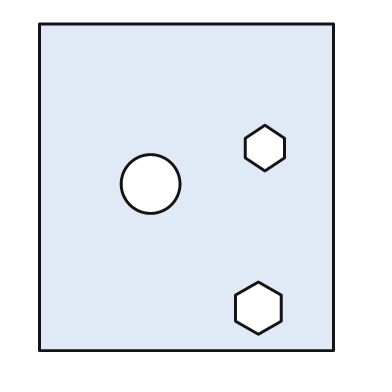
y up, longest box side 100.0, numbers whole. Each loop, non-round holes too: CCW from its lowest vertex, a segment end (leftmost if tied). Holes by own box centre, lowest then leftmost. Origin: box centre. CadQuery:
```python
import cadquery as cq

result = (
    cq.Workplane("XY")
    .moveTo(-45.0, -50.0)
    .lineTo(45.0, -50.0)
    .lineTo(45.0, 50.0)
    .lineTo(-45.0, 50.0)
    .close()
    .moveTo(22.0, -45.0)
    .lineTo(29.0, -41.0)
    .lineTo(29.0, -33.0)
    .lineTo(22.0, -29.0)
    .lineTo(15.0, -33.0)
    .lineTo(15.0, -41.0)
    .close()
    .moveTo(-11.0, 1.0)
    .circle(9.0)
    .moveTo(24.0, 5.0)
    .lineTo(30.0, 9.0)
    .lineTo(30.0, 15.0)
    .lineTo(24.0, 19.0)
    .lineTo(18.0, 15.0)
    .lineTo(18.0, 9.0)
    .close()
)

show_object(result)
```